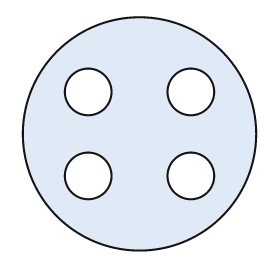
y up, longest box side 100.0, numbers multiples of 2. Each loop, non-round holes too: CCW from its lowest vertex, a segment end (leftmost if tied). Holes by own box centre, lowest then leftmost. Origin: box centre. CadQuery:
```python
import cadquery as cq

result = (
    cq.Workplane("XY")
    .moveTo(0.0, 0.0)
    .circle(50.0)
    .moveTo(-22.0, -18.0)
    .circle(10.0)
    .moveTo(22.0, -18.0)
    .circle(10.0)
    .moveTo(-22.0, 18.0)
    .circle(10.0)
    .moveTo(22.0, 18.0)
    .circle(10.0)
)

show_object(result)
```